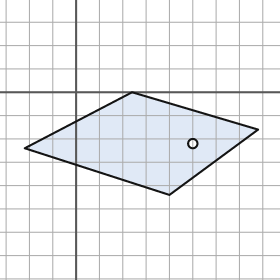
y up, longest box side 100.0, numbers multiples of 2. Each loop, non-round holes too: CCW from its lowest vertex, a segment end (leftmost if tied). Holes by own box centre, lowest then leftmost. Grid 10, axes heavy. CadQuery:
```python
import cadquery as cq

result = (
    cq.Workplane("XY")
    .moveTo(40.0, -44.0)
    .lineTo(78.0, -16.0)
    .lineTo(24.0, 0.0)
    .lineTo(-22.0, -24.0)
    .close()
    .moveTo(50.0, -22.0)
    .circle(2.0)
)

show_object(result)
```